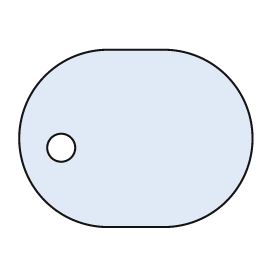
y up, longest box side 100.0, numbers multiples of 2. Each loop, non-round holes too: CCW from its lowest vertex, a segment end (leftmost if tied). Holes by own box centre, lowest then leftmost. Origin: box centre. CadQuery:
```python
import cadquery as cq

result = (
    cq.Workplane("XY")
    .moveTo(-12.0, -38.0)
    .lineTo(12.0, -38.0)
    .threePointArc((50.0, 0.0), (12.0, 38.0))
    .lineTo(-12.0, 38.0)
    .threePointArc((-50.0, 0.0), (-12.0, -38.0))
    .close()
    .moveTo(-32.0, -4.0)
    .circle(6.0)
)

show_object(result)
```